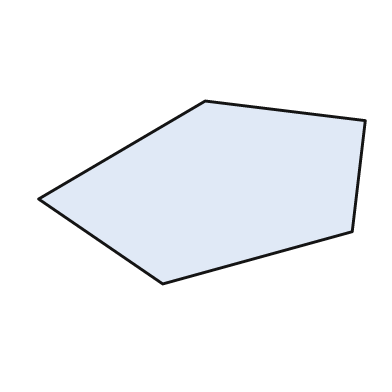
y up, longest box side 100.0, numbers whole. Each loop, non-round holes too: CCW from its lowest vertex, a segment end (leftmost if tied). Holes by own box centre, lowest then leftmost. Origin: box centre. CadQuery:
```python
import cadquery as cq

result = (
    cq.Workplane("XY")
    .moveTo(-12.0, -28.0)
    .lineTo(46.0, -12.0)
    .lineTo(50.0, 22.0)
    .lineTo(1.0, 28.0)
    .lineTo(-50.0, -2.0)
    .close()
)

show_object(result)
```